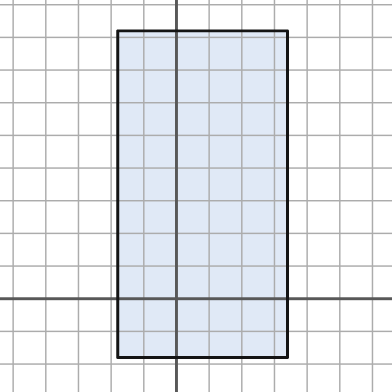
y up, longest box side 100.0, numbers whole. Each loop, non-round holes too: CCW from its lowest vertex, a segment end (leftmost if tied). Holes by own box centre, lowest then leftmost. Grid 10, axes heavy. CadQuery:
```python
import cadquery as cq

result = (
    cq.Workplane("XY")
    .moveTo(-18.0, -18.0)
    .lineTo(34.0, -18.0)
    .lineTo(34.0, 82.0)
    .lineTo(-18.0, 82.0)
    .close()
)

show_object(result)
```